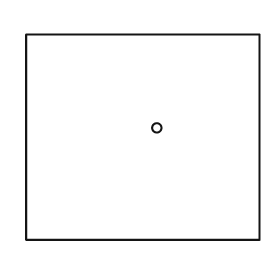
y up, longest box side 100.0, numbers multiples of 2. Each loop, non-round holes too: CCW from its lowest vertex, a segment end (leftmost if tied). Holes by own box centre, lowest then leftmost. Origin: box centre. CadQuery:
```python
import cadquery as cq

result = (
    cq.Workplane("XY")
    .moveTo(-50.0, -44.0)
    .lineTo(50.0, -44.0)
    .lineTo(50.0, 44.0)
    .lineTo(-50.0, 44.0)
    .close()
    .moveTo(6.0, 4.0)
    .circle(2.0)
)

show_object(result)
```